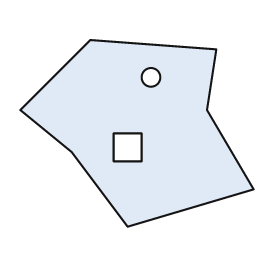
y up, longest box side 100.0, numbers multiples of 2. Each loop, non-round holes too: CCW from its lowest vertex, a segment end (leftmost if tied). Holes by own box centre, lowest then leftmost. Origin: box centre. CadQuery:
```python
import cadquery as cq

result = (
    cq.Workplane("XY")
    .moveTo(-4.0, -40.0)
    .lineTo(50.0, -24.0)
    .lineTo(30.0, 10.0)
    .lineTo(34.0, 36.0)
    .lineTo(-20.0, 40.0)
    .lineTo(-50.0, 10.0)
    .lineTo(-28.0, -8.0)
    .close()
    .moveTo(-10.0, -12.0)
    .lineTo(2.0, -12.0)
    .lineTo(2.0, 0.0)
    .lineTo(-10.0, 0.0)
    .close()
    .moveTo(6.0, 24.0)
    .circle(4.0)
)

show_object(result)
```